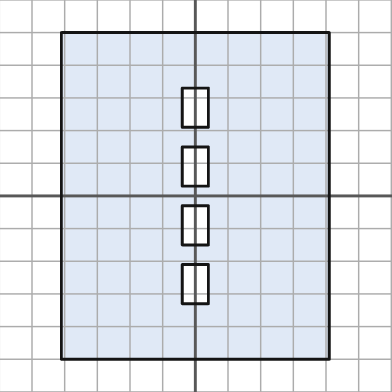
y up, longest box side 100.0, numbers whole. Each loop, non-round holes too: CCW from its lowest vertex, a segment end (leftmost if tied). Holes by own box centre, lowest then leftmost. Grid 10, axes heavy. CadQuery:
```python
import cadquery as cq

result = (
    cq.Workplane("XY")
    .moveTo(-41.0, -50.0)
    .lineTo(41.0, -50.0)
    .lineTo(41.0, 50.0)
    .lineTo(-41.0, 50.0)
    .close()
    .moveTo(-4.0, -33.0)
    .lineTo(4.0, -33.0)
    .lineTo(4.0, -21.0)
    .lineTo(-4.0, -21.0)
    .close()
    .moveTo(-4.0, -15.0)
    .lineTo(4.0, -15.0)
    .lineTo(4.0, -3.0)
    .lineTo(-4.0, -3.0)
    .close()
    .moveTo(-4.0, 3.0)
    .lineTo(4.0, 3.0)
    .lineTo(4.0, 15.0)
    .lineTo(-4.0, 15.0)
    .close()
    .moveTo(-4.0, 21.0)
    .lineTo(4.0, 21.0)
    .lineTo(4.0, 33.0)
    .lineTo(-4.0, 33.0)
    .close()
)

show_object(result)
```